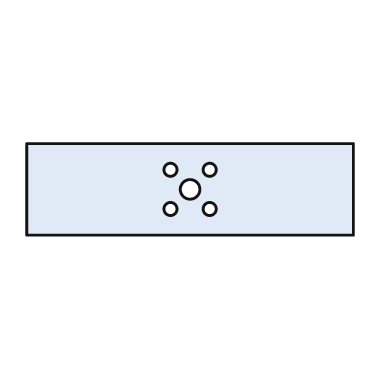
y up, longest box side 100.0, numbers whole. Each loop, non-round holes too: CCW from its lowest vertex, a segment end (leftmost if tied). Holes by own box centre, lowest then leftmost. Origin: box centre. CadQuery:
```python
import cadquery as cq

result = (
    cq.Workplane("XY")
    .moveTo(-50.0, -14.0)
    .lineTo(50.0, -14.0)
    .lineTo(50.0, 14.0)
    .lineTo(-50.0, 14.0)
    .close()
    .moveTo(-6.0, -6.0)
    .circle(2.0)
    .moveTo(6.0, -6.0)
    .circle(2.0)
    .moveTo(0.0, 0.0)
    .circle(3.0)
    .moveTo(-6.0, 6.0)
    .circle(2.0)
    .moveTo(6.0, 6.0)
    .circle(2.0)
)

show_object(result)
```